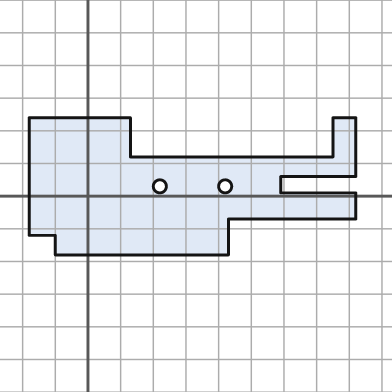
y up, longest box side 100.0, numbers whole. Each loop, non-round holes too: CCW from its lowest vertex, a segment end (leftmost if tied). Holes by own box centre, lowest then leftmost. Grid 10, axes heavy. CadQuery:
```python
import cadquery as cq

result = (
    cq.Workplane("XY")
    .moveTo(-10.0, -18.0)
    .lineTo(43.0, -18.0)
    .lineTo(43.0, -7.0)
    .lineTo(82.0, -7.0)
    .lineTo(82.0, 1.0)
    .lineTo(59.0, 1.0)
    .lineTo(59.0, 6.0)
    .lineTo(82.0, 6.0)
    .lineTo(82.0, 24.0)
    .lineTo(75.0, 24.0)
    .lineTo(75.0, 12.0)
    .lineTo(13.0, 12.0)
    .lineTo(13.0, 24.0)
    .lineTo(-18.0, 24.0)
    .lineTo(-18.0, -12.0)
    .lineTo(-10.0, -12.0)
    .close()
    .moveTo(22.0, 3.0)
    .circle(2.0)
    .moveTo(42.0, 3.0)
    .circle(2.0)
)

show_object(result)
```